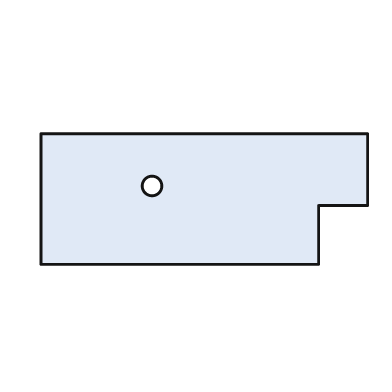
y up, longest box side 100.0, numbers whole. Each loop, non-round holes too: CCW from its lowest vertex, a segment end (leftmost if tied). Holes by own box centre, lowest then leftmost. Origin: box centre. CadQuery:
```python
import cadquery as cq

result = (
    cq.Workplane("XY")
    .moveTo(-50.0, -20.0)
    .lineTo(35.0, -20.0)
    .lineTo(35.0, -2.0)
    .lineTo(50.0, -2.0)
    .lineTo(50.0, 20.0)
    .lineTo(-50.0, 20.0)
    .close()
    .moveTo(-16.0, 4.0)
    .circle(3.0)
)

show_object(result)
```